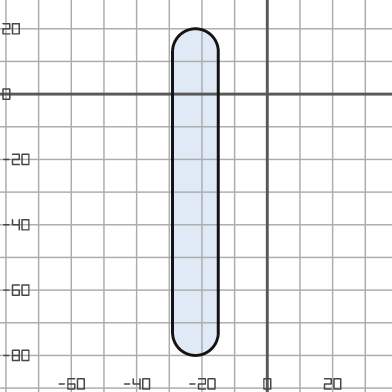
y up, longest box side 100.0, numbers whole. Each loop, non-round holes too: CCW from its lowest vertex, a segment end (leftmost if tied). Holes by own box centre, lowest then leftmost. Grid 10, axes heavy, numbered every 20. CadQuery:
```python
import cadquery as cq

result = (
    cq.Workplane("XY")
    .moveTo(-29.0, -73.0)
    .threePointArc((-22.0, -80.0), (-15.0, -73.0))
    .lineTo(-15.0, 13.0)
    .threePointArc((-22.0, 20.0), (-29.0, 13.0))
    .close()
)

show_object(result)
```